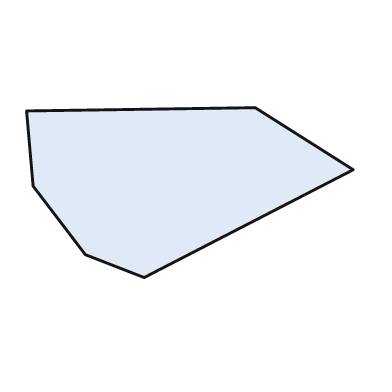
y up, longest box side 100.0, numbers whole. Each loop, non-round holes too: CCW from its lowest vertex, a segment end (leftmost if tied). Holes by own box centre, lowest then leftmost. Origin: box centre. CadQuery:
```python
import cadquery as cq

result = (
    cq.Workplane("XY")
    .moveTo(-14.0, -26.0)
    .lineTo(50.0, 7.0)
    .lineTo(20.0, 26.0)
    .lineTo(-50.0, 25.0)
    .lineTo(-48.0, 2.0)
    .lineTo(-32.0, -19.0)
    .close()
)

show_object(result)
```